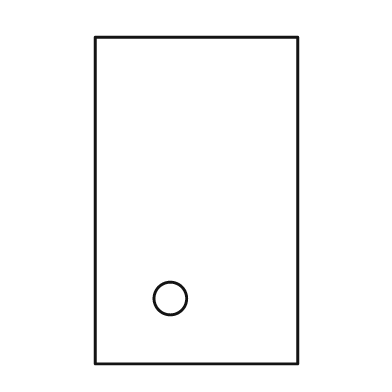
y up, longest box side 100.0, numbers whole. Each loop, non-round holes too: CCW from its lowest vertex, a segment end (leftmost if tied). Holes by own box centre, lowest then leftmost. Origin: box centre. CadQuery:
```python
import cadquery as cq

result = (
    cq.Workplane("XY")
    .moveTo(-31.0, -50.0)
    .lineTo(31.0, -50.0)
    .lineTo(31.0, 50.0)
    .lineTo(-31.0, 50.0)
    .close()
    .moveTo(-8.0, -30.0)
    .circle(5.0)
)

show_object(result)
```